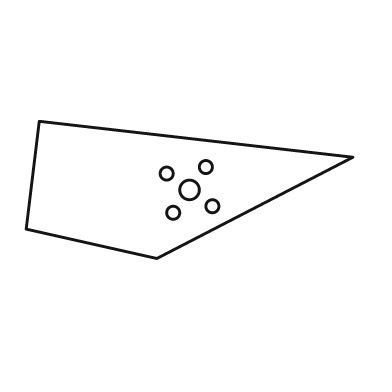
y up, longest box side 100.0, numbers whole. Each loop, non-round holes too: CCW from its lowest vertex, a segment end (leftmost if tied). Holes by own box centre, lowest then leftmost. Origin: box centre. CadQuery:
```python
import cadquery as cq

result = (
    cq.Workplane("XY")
    .moveTo(-10.0, -21.0)
    .lineTo(50.0, 10.0)
    .lineTo(-46.0, 21.0)
    .lineTo(-50.0, -12.0)
    .close()
    .moveTo(-5.0, -7.0)
    .circle(2.0)
    .moveTo(7.0, -5.0)
    .circle(2.0)
    .moveTo(0.0, 0.0)
    .circle(3.0)
    .moveTo(-7.0, 5.0)
    .circle(2.0)
    .moveTo(5.0, 7.0)
    .circle(2.0)
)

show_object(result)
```